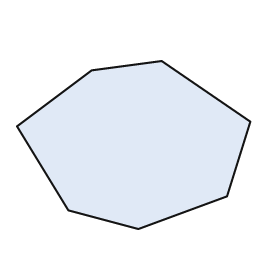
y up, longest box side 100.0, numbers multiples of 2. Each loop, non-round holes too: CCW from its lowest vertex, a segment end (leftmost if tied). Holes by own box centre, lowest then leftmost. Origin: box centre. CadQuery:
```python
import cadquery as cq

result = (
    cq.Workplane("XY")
    .moveTo(2.0, -36.0)
    .lineTo(40.0, -22.0)
    .lineTo(50.0, 10.0)
    .lineTo(12.0, 36.0)
    .lineTo(-18.0, 32.0)
    .lineTo(-50.0, 8.0)
    .lineTo(-28.0, -28.0)
    .close()
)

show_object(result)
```